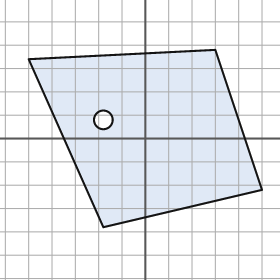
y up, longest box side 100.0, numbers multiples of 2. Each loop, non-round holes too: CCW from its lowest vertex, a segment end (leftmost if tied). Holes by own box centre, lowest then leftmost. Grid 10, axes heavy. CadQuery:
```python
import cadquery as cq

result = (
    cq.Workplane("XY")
    .moveTo(-18.0, -38.0)
    .lineTo(50.0, -22.0)
    .lineTo(30.0, 38.0)
    .lineTo(-50.0, 34.0)
    .close()
    .moveTo(-18.0, 8.0)
    .circle(4.0)
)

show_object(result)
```